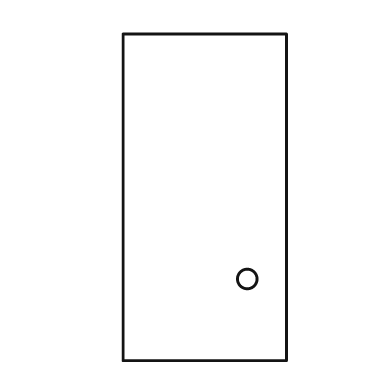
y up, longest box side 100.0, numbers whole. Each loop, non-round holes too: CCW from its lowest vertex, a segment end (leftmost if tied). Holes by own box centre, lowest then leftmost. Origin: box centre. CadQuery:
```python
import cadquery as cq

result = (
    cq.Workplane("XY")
    .moveTo(-25.0, -50.0)
    .lineTo(25.0, -50.0)
    .lineTo(25.0, 50.0)
    .lineTo(-25.0, 50.0)
    .close()
    .moveTo(13.0, -25.0)
    .circle(3.0)
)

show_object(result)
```